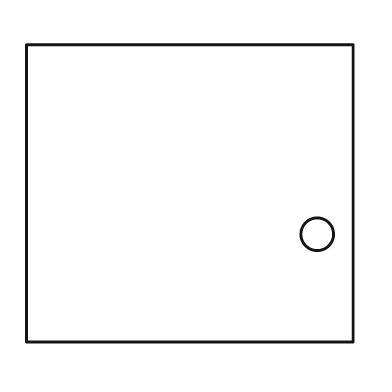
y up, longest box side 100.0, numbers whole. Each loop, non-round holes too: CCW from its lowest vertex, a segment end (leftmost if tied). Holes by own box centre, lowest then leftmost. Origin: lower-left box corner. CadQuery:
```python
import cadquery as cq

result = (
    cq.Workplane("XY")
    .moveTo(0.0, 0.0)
    .lineTo(100.0, 0.0)
    .lineTo(100.0, 91.0)
    .lineTo(0.0, 91.0)
    .close()
    .moveTo(89.0, 33.0)
    .circle(5.0)
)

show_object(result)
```